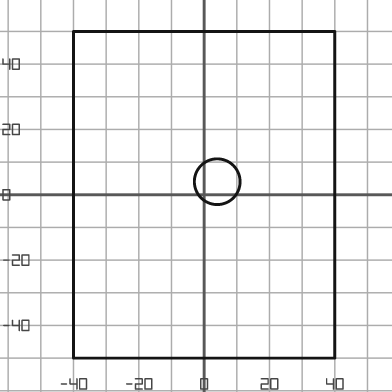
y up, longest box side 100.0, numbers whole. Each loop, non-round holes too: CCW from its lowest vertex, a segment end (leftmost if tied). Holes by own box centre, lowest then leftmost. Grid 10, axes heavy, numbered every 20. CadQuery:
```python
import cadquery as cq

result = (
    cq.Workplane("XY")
    .moveTo(-40.0, -50.0)
    .lineTo(40.0, -50.0)
    .lineTo(40.0, 50.0)
    .lineTo(-40.0, 50.0)
    .close()
    .moveTo(4.0, 4.0)
    .circle(7.0)
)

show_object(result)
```